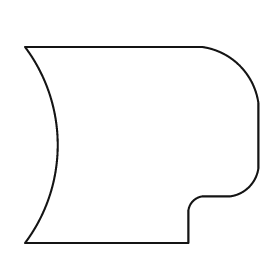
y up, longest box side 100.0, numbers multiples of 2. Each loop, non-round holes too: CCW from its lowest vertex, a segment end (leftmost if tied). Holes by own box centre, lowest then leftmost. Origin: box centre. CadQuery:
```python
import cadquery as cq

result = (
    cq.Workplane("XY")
    .moveTo(-50.0, -42.0)
    .lineTo(20.0, -42.0)
    .lineTo(20.0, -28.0)
    .threePointArc((22.0, -24.0), (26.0, -22.0))
    .lineTo(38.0, -22.0)
    .threePointArc((46.0, -18.0), (50.0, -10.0))
    .lineTo(50.0, 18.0)
    .threePointArc((42.0, 34.0), (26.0, 42.0))
    .lineTo(-50.0, 42.0)
    .threePointArc((-36.0, 0.0), (-50.0, -42.0))
    .close()
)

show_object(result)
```